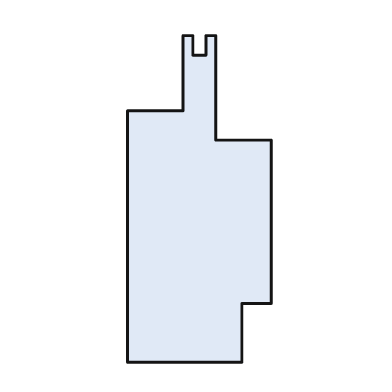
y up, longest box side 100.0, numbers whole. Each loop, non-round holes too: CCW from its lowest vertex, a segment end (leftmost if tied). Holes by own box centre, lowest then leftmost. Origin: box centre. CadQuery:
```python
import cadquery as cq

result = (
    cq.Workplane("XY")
    .moveTo(-22.0, -50.0)
    .lineTo(13.0, -50.0)
    .lineTo(13.0, -32.0)
    .lineTo(22.0, -32.0)
    .lineTo(22.0, 18.0)
    .lineTo(5.0, 18.0)
    .lineTo(5.0, 50.0)
    .lineTo(2.0, 50.0)
    .lineTo(2.0, 44.0)
    .lineTo(-2.0, 44.0)
    .lineTo(-2.0, 50.0)
    .lineTo(-5.0, 50.0)
    .lineTo(-5.0, 27.0)
    .lineTo(-22.0, 27.0)
    .close()
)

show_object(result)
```